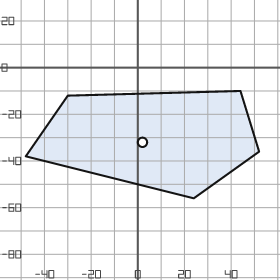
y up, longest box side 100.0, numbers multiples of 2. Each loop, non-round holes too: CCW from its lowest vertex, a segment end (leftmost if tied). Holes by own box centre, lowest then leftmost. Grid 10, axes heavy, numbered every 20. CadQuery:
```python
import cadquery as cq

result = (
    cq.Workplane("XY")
    .moveTo(24.0, -56.0)
    .lineTo(52.0, -36.0)
    .lineTo(44.0, -10.0)
    .lineTo(-30.0, -12.0)
    .lineTo(-48.0, -38.0)
    .close()
    .moveTo(2.0, -32.0)
    .circle(2.0)
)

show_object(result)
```